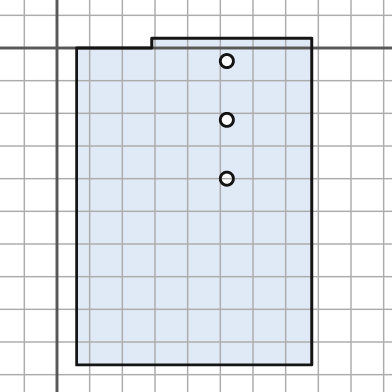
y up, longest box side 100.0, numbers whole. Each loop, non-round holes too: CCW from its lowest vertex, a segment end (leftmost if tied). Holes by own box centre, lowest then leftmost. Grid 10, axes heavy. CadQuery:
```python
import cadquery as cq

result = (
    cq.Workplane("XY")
    .moveTo(6.0, -97.0)
    .lineTo(78.0, -97.0)
    .lineTo(78.0, 3.0)
    .lineTo(29.0, 3.0)
    .lineTo(29.0, 0.0)
    .lineTo(6.0, 0.0)
    .close()
    .moveTo(52.0, -40.0)
    .circle(2.0)
    .moveTo(52.0, -22.0)
    .circle(2.0)
    .moveTo(52.0, -4.0)
    .circle(2.0)
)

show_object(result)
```